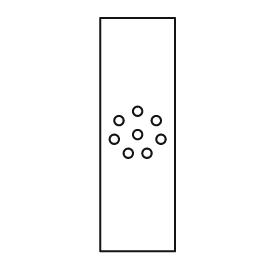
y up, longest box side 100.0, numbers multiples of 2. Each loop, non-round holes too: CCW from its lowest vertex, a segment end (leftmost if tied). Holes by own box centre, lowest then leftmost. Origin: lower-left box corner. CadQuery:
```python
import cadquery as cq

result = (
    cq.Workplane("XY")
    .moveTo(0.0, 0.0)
    .lineTo(32.0, 0.0)
    .lineTo(32.0, 100.0)
    .lineTo(0.0, 100.0)
    .close()
    .moveTo(12.0, 42.0)
    .circle(2.0)
    .moveTo(20.0, 42.0)
    .circle(2.0)
    .moveTo(6.0, 48.0)
    .circle(2.0)
    .moveTo(26.0, 48.0)
    .circle(2.0)
    .moveTo(16.0, 50.0)
    .circle(2.0)
    .moveTo(8.0, 56.0)
    .circle(2.0)
    .moveTo(24.0, 56.0)
    .circle(2.0)
    .moveTo(16.0, 60.0)
    .circle(2.0)
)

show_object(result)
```